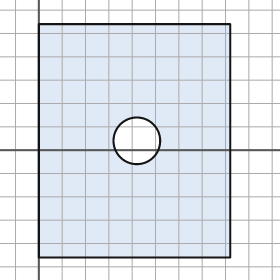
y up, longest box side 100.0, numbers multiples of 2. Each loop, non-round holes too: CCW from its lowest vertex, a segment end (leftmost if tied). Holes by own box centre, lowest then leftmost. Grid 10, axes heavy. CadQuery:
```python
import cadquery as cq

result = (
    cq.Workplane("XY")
    .moveTo(0.0, -46.0)
    .lineTo(82.0, -46.0)
    .lineTo(82.0, 54.0)
    .lineTo(0.0, 54.0)
    .close()
    .moveTo(42.0, 4.0)
    .circle(10.0)
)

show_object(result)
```